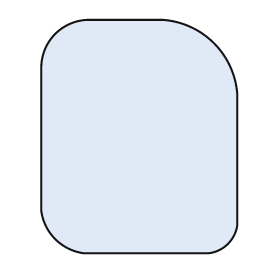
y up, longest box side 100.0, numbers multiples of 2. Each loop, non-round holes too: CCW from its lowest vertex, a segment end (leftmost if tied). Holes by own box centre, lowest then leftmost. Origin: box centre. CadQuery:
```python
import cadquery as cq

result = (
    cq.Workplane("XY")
    .moveTo(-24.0, -50.0)
    .lineTo(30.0, -50.0)
    .threePointArc((38.0, -46.0), (42.0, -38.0))
    .lineTo(42.0, 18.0)
    .threePointArc((32.0, 40.0), (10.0, 50.0))
    .lineTo(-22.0, 50.0)
    .threePointArc((-36.0, 44.0), (-42.0, 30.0))
    .lineTo(-42.0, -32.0)
    .threePointArc((-36.0, -44.0), (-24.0, -50.0))
    .close()
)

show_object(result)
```